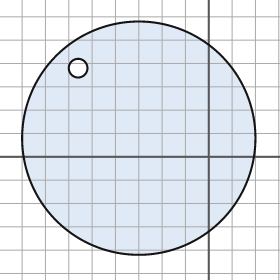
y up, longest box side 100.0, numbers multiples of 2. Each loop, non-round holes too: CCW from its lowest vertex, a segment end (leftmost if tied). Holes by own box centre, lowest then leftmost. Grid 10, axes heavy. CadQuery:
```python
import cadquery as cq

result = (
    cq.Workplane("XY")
    .moveTo(-30.0, 8.0)
    .circle(50.0)
    .moveTo(-56.0, 38.0)
    .circle(4.0)
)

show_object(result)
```